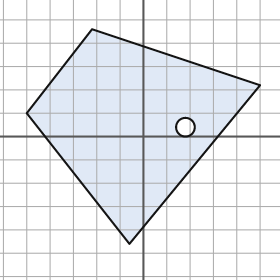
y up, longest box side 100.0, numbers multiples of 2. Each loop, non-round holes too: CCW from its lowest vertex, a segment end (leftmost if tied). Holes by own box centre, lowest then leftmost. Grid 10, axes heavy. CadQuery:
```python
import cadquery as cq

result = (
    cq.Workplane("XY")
    .moveTo(-6.0, -46.0)
    .lineTo(50.0, 22.0)
    .lineTo(-22.0, 46.0)
    .lineTo(-50.0, 10.0)
    .close()
    .moveTo(18.0, 4.0)
    .circle(4.0)
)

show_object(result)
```